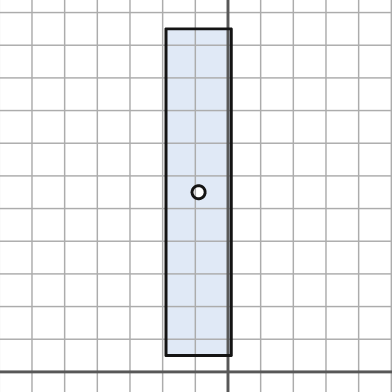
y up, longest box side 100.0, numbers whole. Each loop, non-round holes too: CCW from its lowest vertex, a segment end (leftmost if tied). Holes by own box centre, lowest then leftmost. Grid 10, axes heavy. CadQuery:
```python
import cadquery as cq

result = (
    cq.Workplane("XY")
    .moveTo(-19.0, 5.0)
    .lineTo(1.0, 5.0)
    .lineTo(1.0, 105.0)
    .lineTo(-19.0, 105.0)
    .close()
    .moveTo(-9.0, 55.0)
    .circle(2.0)
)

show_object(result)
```